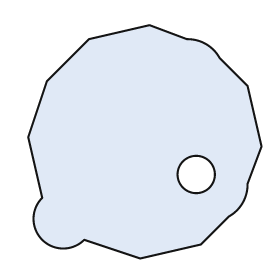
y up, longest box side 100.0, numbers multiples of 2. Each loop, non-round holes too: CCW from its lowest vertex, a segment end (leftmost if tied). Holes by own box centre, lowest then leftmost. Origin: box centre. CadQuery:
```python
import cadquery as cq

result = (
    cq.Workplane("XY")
    .moveTo(-2.0, -50.0)
    .lineTo(24.0, -44.0)
    .lineTo(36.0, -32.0)
    .threePointArc((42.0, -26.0), (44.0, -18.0))
    .lineTo(50.0, -2.0)
    .lineTo(44.0, 24.0)
    .lineTo(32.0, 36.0)
    .threePointArc((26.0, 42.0), (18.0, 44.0))
    .lineTo(2.0, 50.0)
    .lineTo(-24.0, 44.0)
    .lineTo(-42.0, 26.0)
    .lineTo(-50.0, 2.0)
    .lineTo(-44.0, -24.0)
    .threePointArc((-44.0, -42.0), (-26.0, -42.0))
    .close()
    .moveTo(22.0, -14.0)
    .circle(8.0)
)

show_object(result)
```